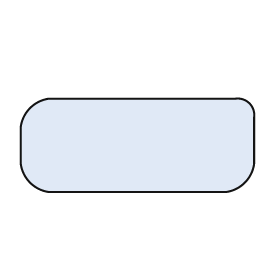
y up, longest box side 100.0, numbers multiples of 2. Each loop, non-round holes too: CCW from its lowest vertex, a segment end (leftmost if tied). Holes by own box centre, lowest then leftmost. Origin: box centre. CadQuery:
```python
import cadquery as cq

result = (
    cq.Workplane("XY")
    .moveTo(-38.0, -20.0)
    .lineTo(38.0, -20.0)
    .threePointArc((46.0, -16.0), (50.0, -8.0))
    .lineTo(50.0, 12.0)
    .threePointArc((48.0, 18.0), (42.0, 20.0))
    .lineTo(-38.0, 20.0)
    .threePointArc((-46.0, 16.0), (-50.0, 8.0))
    .lineTo(-50.0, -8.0)
    .threePointArc((-46.0, -16.0), (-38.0, -20.0))
    .close()
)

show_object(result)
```